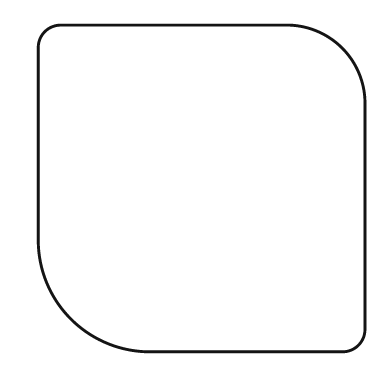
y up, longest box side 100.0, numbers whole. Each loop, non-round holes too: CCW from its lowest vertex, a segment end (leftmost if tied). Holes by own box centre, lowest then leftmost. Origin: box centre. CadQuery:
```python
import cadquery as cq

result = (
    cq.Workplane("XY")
    .moveTo(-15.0, -50.0)
    .lineTo(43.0, -50.0)
    .threePointArc((48.0, -48.0), (50.0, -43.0))
    .lineTo(50.0, 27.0)
    .threePointArc((43.0, 43.0), (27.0, 50.0))
    .lineTo(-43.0, 50.0)
    .threePointArc((-48.0, 48.0), (-50.0, 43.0))
    .lineTo(-50.0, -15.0)
    .threePointArc((-40.0, -40.0), (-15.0, -50.0))
    .close()
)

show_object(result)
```